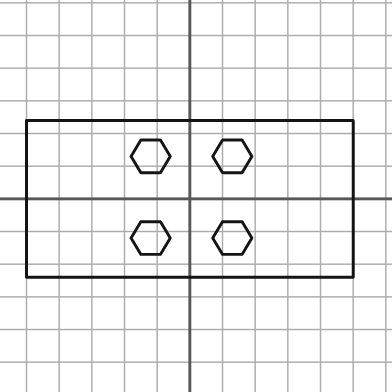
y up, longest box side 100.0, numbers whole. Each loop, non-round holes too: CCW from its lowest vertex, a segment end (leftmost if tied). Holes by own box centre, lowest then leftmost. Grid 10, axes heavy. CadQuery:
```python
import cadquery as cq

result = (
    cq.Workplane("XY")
    .moveTo(-50.0, -24.0)
    .lineTo(50.0, -24.0)
    .lineTo(50.0, 24.0)
    .lineTo(-50.0, 24.0)
    .close()
    .moveTo(-15.0, -17.0)
    .lineTo(-9.0, -17.0)
    .lineTo(-6.0, -12.0)
    .lineTo(-9.0, -7.0)
    .lineTo(-15.0, -7.0)
    .lineTo(-18.0, -12.0)
    .close()
    .moveTo(10.0, -17.0)
    .lineTo(16.0, -17.0)
    .lineTo(19.0, -12.0)
    .lineTo(16.0, -7.0)
    .lineTo(10.0, -7.0)
    .lineTo(7.0, -12.0)
    .close()
    .moveTo(-15.0, 8.0)
    .lineTo(-9.0, 8.0)
    .lineTo(-6.0, 13.0)
    .lineTo(-9.0, 18.0)
    .lineTo(-15.0, 18.0)
    .lineTo(-18.0, 13.0)
    .close()
    .moveTo(10.0, 8.0)
    .lineTo(16.0, 8.0)
    .lineTo(19.0, 13.0)
    .lineTo(16.0, 18.0)
    .lineTo(10.0, 18.0)
    .lineTo(7.0, 13.0)
    .close()
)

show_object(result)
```